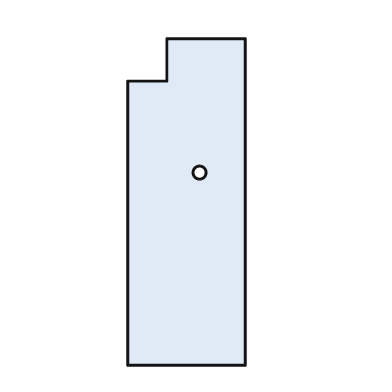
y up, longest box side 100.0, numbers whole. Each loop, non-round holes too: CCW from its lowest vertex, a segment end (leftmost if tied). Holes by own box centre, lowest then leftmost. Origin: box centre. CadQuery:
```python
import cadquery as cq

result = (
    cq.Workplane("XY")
    .moveTo(-18.0, -50.0)
    .lineTo(18.0, -50.0)
    .lineTo(18.0, 50.0)
    .lineTo(-6.0, 50.0)
    .lineTo(-6.0, 37.0)
    .lineTo(-18.0, 37.0)
    .close()
    .moveTo(4.0, 9.0)
    .circle(2.0)
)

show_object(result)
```